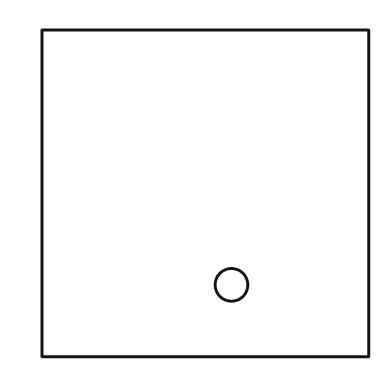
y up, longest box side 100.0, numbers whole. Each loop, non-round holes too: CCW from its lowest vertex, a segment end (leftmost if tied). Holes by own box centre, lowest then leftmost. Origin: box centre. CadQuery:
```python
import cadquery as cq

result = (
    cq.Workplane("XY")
    .moveTo(-50.0, -50.0)
    .lineTo(50.0, -50.0)
    .lineTo(50.0, 50.0)
    .lineTo(-50.0, 50.0)
    .close()
    .moveTo(8.0, -28.0)
    .circle(5.0)
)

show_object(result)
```